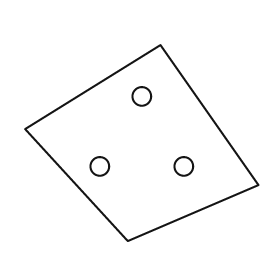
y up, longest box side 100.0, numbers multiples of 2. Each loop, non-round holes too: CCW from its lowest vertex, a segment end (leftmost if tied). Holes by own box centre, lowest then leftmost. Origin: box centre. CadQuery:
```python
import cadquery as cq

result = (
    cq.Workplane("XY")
    .moveTo(-6.0, -42.0)
    .lineTo(50.0, -18.0)
    .lineTo(8.0, 42.0)
    .lineTo(-50.0, 6.0)
    .close()
    .moveTo(-18.0, -10.0)
    .circle(4.0)
    .moveTo(18.0, -10.0)
    .circle(4.0)
    .moveTo(0.0, 20.0)
    .circle(4.0)
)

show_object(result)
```